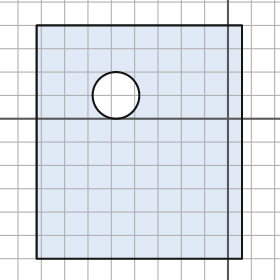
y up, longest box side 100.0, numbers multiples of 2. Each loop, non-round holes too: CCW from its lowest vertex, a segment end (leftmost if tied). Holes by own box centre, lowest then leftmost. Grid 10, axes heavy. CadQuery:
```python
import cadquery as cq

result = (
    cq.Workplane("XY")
    .moveTo(-82.0, -60.0)
    .lineTo(6.0, -60.0)
    .lineTo(6.0, 40.0)
    .lineTo(-82.0, 40.0)
    .close()
    .moveTo(-48.0, 10.0)
    .circle(10.0)
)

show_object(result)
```